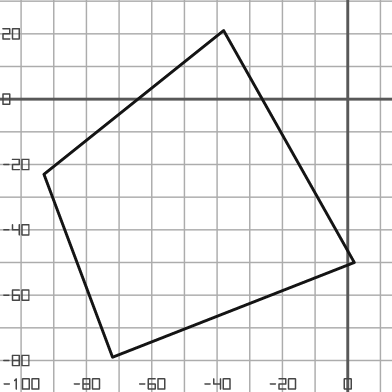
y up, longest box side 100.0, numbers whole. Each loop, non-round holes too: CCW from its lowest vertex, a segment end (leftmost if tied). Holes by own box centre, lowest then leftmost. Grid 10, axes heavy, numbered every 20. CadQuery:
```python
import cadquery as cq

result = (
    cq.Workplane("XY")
    .moveTo(-72.0, -79.0)
    .lineTo(2.0, -50.0)
    .lineTo(-38.0, 21.0)
    .lineTo(-93.0, -23.0)
    .close()
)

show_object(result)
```